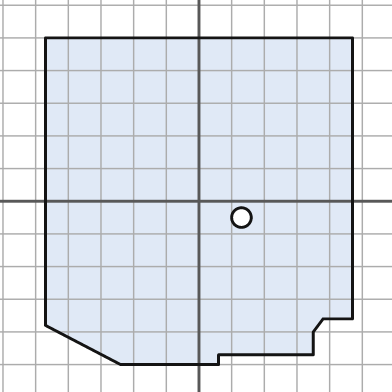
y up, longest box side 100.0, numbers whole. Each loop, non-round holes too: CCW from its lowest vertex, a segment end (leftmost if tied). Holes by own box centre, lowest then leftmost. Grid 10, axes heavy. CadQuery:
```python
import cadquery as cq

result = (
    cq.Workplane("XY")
    .moveTo(-24.0, -50.0)
    .lineTo(6.0, -50.0)
    .lineTo(6.0, -47.0)
    .lineTo(35.0, -47.0)
    .lineTo(35.0, -40.0)
    .lineTo(38.0, -36.0)
    .lineTo(47.0, -36.0)
    .lineTo(47.0, 50.0)
    .lineTo(-47.0, 50.0)
    .lineTo(-47.0, -38.0)
    .close()
    .moveTo(13.0, -5.0)
    .circle(3.0)
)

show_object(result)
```